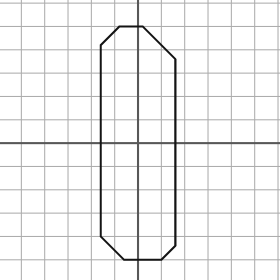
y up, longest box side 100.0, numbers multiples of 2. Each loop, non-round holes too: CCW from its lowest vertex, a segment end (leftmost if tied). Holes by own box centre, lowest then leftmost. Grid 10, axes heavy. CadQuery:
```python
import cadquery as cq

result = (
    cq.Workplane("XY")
    .moveTo(-6.0, -50.0)
    .lineTo(10.0, -50.0)
    .lineTo(16.0, -44.0)
    .lineTo(16.0, 36.0)
    .lineTo(2.0, 50.0)
    .lineTo(-8.0, 50.0)
    .lineTo(-16.0, 42.0)
    .lineTo(-16.0, -40.0)
    .close()
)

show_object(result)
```